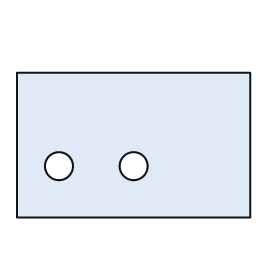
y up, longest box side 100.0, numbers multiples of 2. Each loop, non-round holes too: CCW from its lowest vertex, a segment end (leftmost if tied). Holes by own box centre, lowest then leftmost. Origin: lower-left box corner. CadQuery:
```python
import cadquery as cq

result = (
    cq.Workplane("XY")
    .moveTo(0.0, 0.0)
    .lineTo(100.0, 0.0)
    .lineTo(100.0, 62.0)
    .lineTo(0.0, 62.0)
    .close()
    .moveTo(18.0, 22.0)
    .circle(6.0)
    .moveTo(50.0, 22.0)
    .circle(6.0)
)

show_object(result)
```